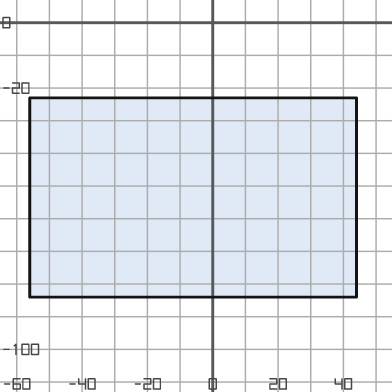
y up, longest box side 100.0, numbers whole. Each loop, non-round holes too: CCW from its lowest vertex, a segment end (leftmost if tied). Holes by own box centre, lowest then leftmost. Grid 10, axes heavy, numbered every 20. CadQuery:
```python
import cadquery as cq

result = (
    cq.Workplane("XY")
    .moveTo(-56.0, -84.0)
    .lineTo(44.0, -84.0)
    .lineTo(44.0, -23.0)
    .lineTo(-56.0, -23.0)
    .close()
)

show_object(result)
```